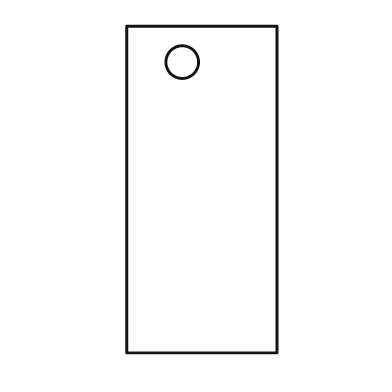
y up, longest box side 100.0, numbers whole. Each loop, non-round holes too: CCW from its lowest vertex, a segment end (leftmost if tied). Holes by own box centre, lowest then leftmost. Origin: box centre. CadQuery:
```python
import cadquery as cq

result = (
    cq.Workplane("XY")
    .moveTo(-23.0, -50.0)
    .lineTo(23.0, -50.0)
    .lineTo(23.0, 50.0)
    .lineTo(-23.0, 50.0)
    .close()
    .moveTo(-6.0, 39.0)
    .circle(5.0)
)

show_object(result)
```